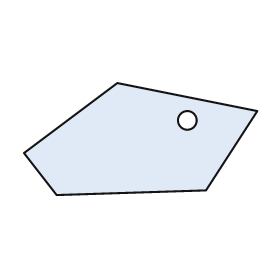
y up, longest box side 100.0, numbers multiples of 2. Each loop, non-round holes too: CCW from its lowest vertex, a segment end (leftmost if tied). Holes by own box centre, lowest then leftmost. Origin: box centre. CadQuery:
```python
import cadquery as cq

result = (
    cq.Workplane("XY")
    .moveTo(-36.0, -24.0)
    .lineTo(28.0, -22.0)
    .lineTo(50.0, 12.0)
    .lineTo(-10.0, 24.0)
    .lineTo(-50.0, -6.0)
    .close()
    .moveTo(20.0, 8.0)
    .circle(4.0)
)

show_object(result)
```